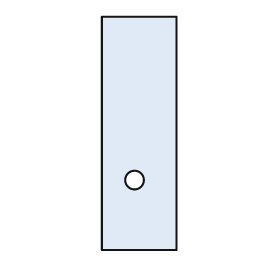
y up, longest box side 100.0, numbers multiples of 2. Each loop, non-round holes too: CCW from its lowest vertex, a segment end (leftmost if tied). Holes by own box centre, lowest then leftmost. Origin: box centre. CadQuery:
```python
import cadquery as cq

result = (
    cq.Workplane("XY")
    .moveTo(-16.0, -50.0)
    .lineTo(16.0, -50.0)
    .lineTo(16.0, 50.0)
    .lineTo(-16.0, 50.0)
    .close()
    .moveTo(-2.0, -20.0)
    .circle(4.0)
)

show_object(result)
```